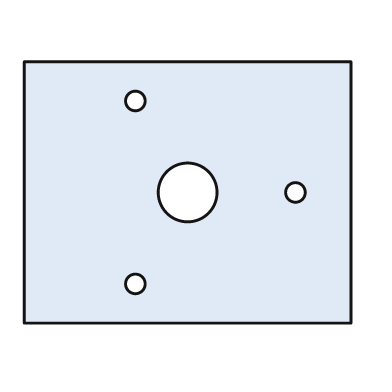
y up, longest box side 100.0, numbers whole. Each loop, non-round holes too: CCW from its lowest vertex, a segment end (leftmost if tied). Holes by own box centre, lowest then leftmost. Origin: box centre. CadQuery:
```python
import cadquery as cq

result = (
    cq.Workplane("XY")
    .moveTo(-50.0, -40.0)
    .lineTo(50.0, -40.0)
    .lineTo(50.0, 40.0)
    .lineTo(-50.0, 40.0)
    .close()
    .moveTo(-16.0, -28.0)
    .circle(3.0)
    .moveTo(0.0, 0.0)
    .circle(9.0)
    .moveTo(33.0, 0.0)
    .circle(3.0)
    .moveTo(-16.0, 28.0)
    .circle(3.0)
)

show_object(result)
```